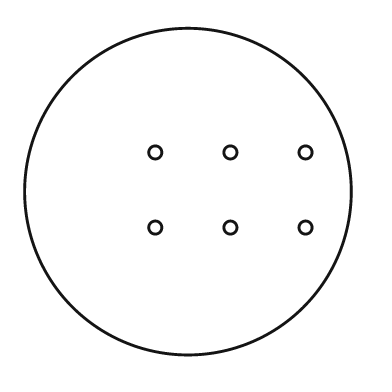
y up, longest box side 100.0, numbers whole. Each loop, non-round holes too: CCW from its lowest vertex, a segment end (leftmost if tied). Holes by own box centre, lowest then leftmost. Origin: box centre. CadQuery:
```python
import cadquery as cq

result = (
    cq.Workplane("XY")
    .moveTo(0.0, 0.0)
    .circle(50.0)
    .moveTo(-10.0, -11.0)
    .circle(2.0)
    .moveTo(13.0, -11.0)
    .circle(2.0)
    .moveTo(36.0, -11.0)
    .circle(2.0)
    .moveTo(-10.0, 12.0)
    .circle(2.0)
    .moveTo(13.0, 12.0)
    .circle(2.0)
    .moveTo(36.0, 12.0)
    .circle(2.0)
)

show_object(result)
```